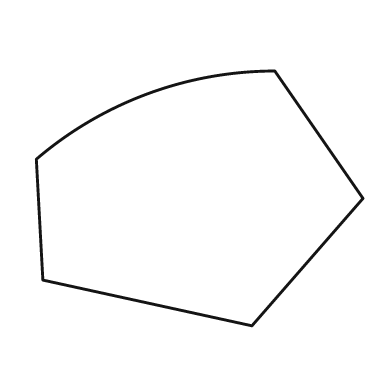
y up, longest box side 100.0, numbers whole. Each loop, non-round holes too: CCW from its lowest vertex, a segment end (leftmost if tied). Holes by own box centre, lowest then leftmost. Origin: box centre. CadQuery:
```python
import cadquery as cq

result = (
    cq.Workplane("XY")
    .moveTo(16.0, -39.0)
    .lineTo(50.0, 0.0)
    .lineTo(23.0, 39.0)
    .threePointArc((-16.0, 32.0), (-50.0, 12.0))
    .lineTo(-48.0, -25.0)
    .close()
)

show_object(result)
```